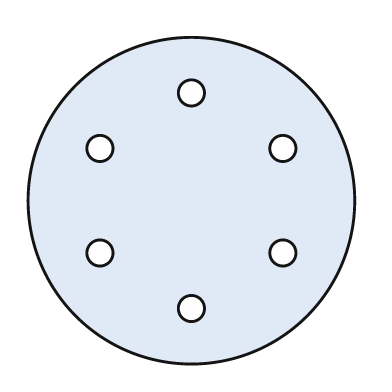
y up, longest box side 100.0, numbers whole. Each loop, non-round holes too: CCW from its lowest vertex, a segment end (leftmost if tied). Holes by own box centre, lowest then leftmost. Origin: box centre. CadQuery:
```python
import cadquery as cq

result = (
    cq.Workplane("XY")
    .moveTo(0.0, 0.0)
    .circle(50.0)
    .moveTo(0.0, -33.0)
    .circle(4.0)
    .moveTo(-28.0, -16.0)
    .circle(4.0)
    .moveTo(28.0, -16.0)
    .circle(4.0)
    .moveTo(-28.0, 16.0)
    .circle(4.0)
    .moveTo(28.0, 16.0)
    .circle(4.0)
    .moveTo(0.0, 33.0)
    .circle(4.0)
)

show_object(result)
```